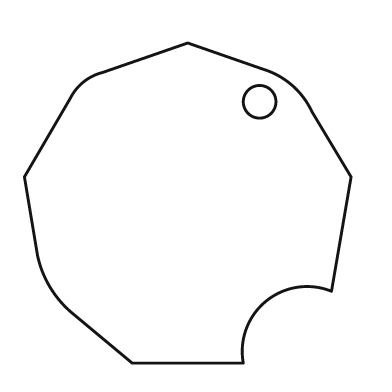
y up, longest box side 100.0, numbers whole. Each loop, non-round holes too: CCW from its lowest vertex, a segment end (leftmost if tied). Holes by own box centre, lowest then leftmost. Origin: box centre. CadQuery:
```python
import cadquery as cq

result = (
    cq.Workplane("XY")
    .moveTo(-17.0, -49.0)
    .lineTo(17.0, -49.0)
    .threePointArc((24.0, -30.0), (44.0, -27.0))
    .lineTo(50.0, 8.0)
    .lineTo(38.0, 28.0)
    .threePointArc((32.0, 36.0), (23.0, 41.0))
    .lineTo(0.0, 49.0)
    .lineTo(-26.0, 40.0)
    .threePointArc((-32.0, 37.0), (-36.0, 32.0))
    .lineTo(-50.0, 8.0)
    .lineTo(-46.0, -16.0)
    .threePointArc((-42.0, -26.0), (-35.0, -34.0))
    .close()
    .moveTo(22.0, 31.0)
    .circle(5.0)
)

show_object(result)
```